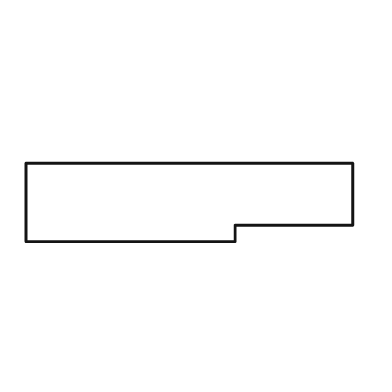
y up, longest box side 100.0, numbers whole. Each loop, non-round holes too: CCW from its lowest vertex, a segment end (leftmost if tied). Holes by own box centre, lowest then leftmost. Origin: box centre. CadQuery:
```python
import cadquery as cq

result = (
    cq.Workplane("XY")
    .moveTo(-50.0, -12.0)
    .lineTo(14.0, -12.0)
    .lineTo(14.0, -7.0)
    .lineTo(50.0, -7.0)
    .lineTo(50.0, 12.0)
    .lineTo(-50.0, 12.0)
    .close()
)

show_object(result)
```